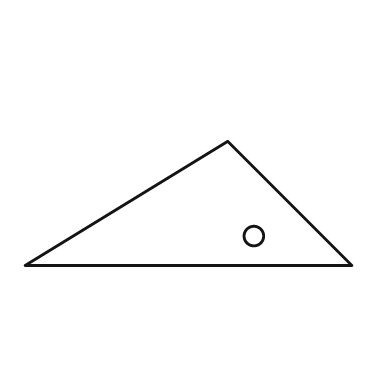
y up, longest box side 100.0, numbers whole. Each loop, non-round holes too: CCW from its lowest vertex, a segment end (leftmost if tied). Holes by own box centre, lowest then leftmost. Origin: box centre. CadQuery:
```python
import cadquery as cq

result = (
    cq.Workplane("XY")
    .moveTo(-50.0, -19.0)
    .lineTo(50.0, -19.0)
    .lineTo(12.0, 19.0)
    .close()
    .moveTo(20.0, -10.0)
    .circle(3.0)
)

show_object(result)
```